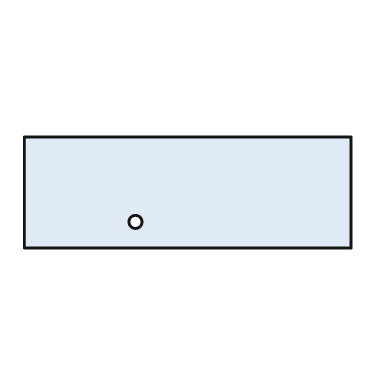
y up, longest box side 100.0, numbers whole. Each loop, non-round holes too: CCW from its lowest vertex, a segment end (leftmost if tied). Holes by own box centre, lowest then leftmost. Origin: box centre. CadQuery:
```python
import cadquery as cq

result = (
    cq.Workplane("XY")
    .moveTo(-50.0, -17.0)
    .lineTo(50.0, -17.0)
    .lineTo(50.0, 17.0)
    .lineTo(-50.0, 17.0)
    .close()
    .moveTo(-16.0, -9.0)
    .circle(2.0)
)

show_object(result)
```